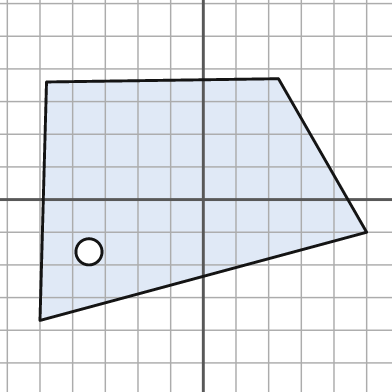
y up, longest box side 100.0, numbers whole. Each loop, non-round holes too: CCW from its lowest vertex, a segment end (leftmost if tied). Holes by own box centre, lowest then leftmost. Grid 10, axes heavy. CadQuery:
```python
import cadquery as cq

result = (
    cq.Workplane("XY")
    .moveTo(-50.0, -37.0)
    .lineTo(50.0, -10.0)
    .lineTo(23.0, 37.0)
    .lineTo(-48.0, 36.0)
    .close()
    .moveTo(-35.0, -16.0)
    .circle(4.0)
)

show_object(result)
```